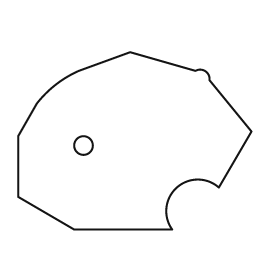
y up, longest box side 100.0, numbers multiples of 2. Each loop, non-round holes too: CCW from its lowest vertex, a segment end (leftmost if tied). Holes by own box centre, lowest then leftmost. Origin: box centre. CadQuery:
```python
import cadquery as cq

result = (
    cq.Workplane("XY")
    .moveTo(-26.0, -38.0)
    .lineTo(16.0, -38.0)
    .threePointArc((18.0, -20.0), (36.0, -20.0))
    .lineTo(50.0, 4.0)
    .lineTo(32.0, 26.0)
    .threePointArc((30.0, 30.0), (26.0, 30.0))
    .lineTo(-2.0, 38.0)
    .lineTo(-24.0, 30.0)
    .threePointArc((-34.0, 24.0), (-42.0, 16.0))
    .lineTo(-50.0, 2.0)
    .lineTo(-50.0, -24.0)
    .close()
    .moveTo(-22.0, -2.0)
    .circle(4.0)
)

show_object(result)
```